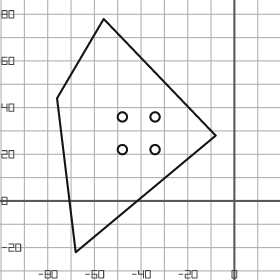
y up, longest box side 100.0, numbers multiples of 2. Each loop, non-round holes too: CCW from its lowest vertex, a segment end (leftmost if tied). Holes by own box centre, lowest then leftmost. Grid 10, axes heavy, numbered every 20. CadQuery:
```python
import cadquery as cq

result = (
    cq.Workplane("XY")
    .moveTo(-68.0, -22.0)
    .lineTo(-8.0, 28.0)
    .lineTo(-56.0, 78.0)
    .lineTo(-76.0, 44.0)
    .close()
    .moveTo(-48.0, 22.0)
    .circle(2.0)
    .moveTo(-34.0, 22.0)
    .circle(2.0)
    .moveTo(-48.0, 36.0)
    .circle(2.0)
    .moveTo(-34.0, 36.0)
    .circle(2.0)
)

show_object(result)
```